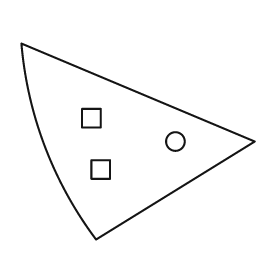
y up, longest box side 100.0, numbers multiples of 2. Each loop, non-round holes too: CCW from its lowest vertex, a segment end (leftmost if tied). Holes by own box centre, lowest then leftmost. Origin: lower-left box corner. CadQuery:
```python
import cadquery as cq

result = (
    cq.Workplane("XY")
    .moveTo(32.0, 0.0)
    .lineTo(100.0, 42.0)
    .lineTo(0.0, 84.0)
    .threePointArc((10.0, 40.0), (32.0, 0.0))
    .close()
    .moveTo(30.0, 26.0)
    .lineTo(38.0, 26.0)
    .lineTo(38.0, 34.0)
    .lineTo(30.0, 34.0)
    .close()
    .moveTo(66.0, 42.0)
    .circle(4.0)
    .moveTo(26.0, 48.0)
    .lineTo(34.0, 48.0)
    .lineTo(34.0, 56.0)
    .lineTo(26.0, 56.0)
    .close()
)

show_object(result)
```